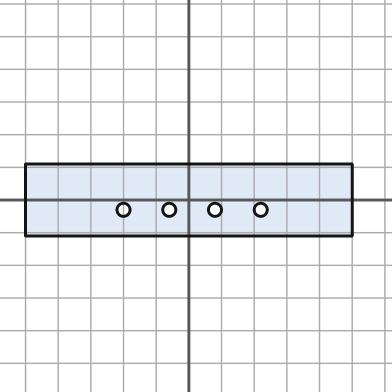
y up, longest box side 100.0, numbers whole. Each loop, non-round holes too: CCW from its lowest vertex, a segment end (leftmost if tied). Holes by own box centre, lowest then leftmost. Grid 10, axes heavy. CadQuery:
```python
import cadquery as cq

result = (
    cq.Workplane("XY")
    .moveTo(-50.0, -11.0)
    .lineTo(50.0, -11.0)
    .lineTo(50.0, 11.0)
    .lineTo(-50.0, 11.0)
    .close()
    .moveTo(-20.0, -3.0)
    .circle(2.0)
    .moveTo(-6.0, -3.0)
    .circle(2.0)
    .moveTo(8.0, -3.0)
    .circle(2.0)
    .moveTo(22.0, -3.0)
    .circle(2.0)
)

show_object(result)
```